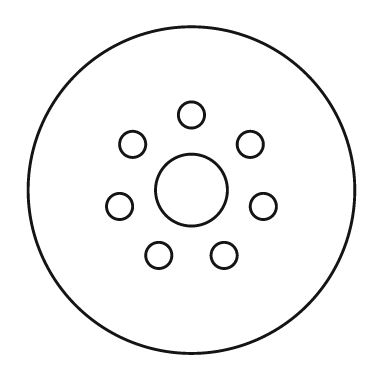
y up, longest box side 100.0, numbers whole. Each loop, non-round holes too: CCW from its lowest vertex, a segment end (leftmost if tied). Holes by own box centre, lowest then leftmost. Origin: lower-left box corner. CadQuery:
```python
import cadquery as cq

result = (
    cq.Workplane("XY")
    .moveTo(50.0, 50.0)
    .circle(50.0)
    .moveTo(40.0, 30.0)
    .circle(4.0)
    .moveTo(60.0, 30.0)
    .circle(4.0)
    .moveTo(28.0, 45.0)
    .circle(4.0)
    .moveTo(72.0, 45.0)
    .circle(4.0)
    .moveTo(50.0, 50.0)
    .circle(11.0)
    .moveTo(32.0, 64.0)
    .circle(4.0)
    .moveTo(68.0, 64.0)
    .circle(4.0)
    .moveTo(50.0, 73.0)
    .circle(4.0)
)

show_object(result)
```